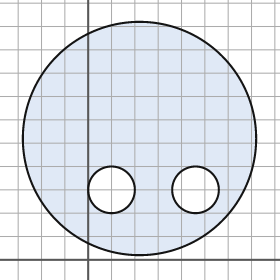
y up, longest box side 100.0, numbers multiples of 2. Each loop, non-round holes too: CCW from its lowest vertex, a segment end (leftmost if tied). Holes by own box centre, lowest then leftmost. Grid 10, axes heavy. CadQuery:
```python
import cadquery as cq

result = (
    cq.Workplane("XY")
    .moveTo(22.0, 52.0)
    .circle(50.0)
    .moveTo(10.0, 30.0)
    .circle(10.0)
    .moveTo(46.0, 30.0)
    .circle(10.0)
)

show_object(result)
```